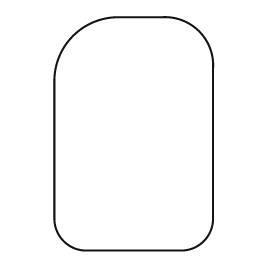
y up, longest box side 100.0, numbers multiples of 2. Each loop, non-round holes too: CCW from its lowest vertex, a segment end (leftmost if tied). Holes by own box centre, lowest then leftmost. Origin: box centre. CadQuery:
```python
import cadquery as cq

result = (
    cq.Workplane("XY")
    .moveTo(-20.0, -50.0)
    .lineTo(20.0, -50.0)
    .threePointArc((30.0, -46.0), (34.0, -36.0))
    .lineTo(34.0, 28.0)
    .threePointArc((28.0, 44.0), (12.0, 50.0))
    .lineTo(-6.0, 50.0)
    .threePointArc((-26.0, 42.0), (-34.0, 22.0))
    .lineTo(-34.0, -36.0)
    .threePointArc((-30.0, -46.0), (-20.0, -50.0))
    .close()
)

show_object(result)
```